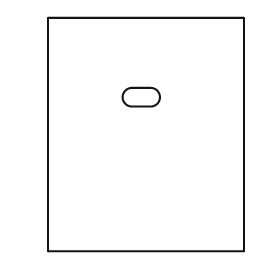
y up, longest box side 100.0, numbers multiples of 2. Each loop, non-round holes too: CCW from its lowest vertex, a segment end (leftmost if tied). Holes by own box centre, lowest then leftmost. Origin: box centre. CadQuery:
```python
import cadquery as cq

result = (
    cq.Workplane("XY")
    .moveTo(-42.0, -50.0)
    .lineTo(42.0, -50.0)
    .lineTo(42.0, 50.0)
    .lineTo(-42.0, 50.0)
    .close()
    .moveTo(-6.0, 12.0)
    .lineTo(2.0, 12.0)
    .threePointArc((6.0, 16.0), (2.0, 20.0))
    .lineTo(-6.0, 20.0)
    .threePointArc((-10.0, 16.0), (-6.0, 12.0))
    .close()
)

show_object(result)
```